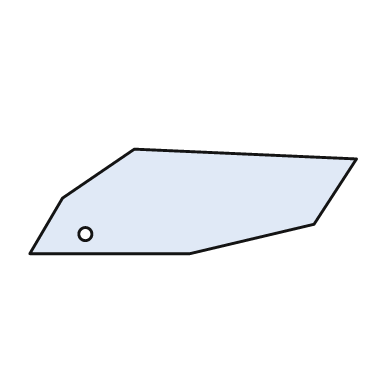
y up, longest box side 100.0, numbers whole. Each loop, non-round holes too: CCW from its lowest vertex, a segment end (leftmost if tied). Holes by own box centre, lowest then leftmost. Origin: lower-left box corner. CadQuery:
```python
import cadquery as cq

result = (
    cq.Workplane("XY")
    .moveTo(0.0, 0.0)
    .lineTo(49.0, 0.0)
    .lineTo(87.0, 9.0)
    .lineTo(100.0, 29.0)
    .lineTo(32.0, 32.0)
    .lineTo(10.0, 17.0)
    .close()
    .moveTo(17.0, 6.0)
    .circle(2.0)
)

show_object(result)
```